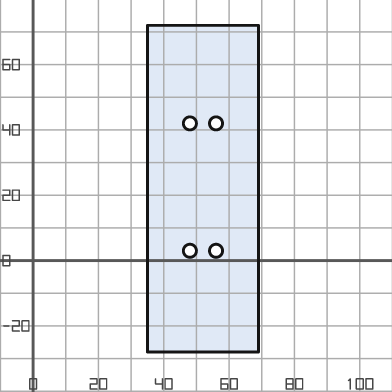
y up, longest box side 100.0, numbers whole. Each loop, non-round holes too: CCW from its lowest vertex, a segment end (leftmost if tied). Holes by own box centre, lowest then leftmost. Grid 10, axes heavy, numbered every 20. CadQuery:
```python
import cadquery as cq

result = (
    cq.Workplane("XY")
    .moveTo(35.0, -28.0)
    .lineTo(69.0, -28.0)
    .lineTo(69.0, 72.0)
    .lineTo(35.0, 72.0)
    .close()
    .moveTo(48.0, 3.0)
    .circle(2.0)
    .moveTo(56.0, 3.0)
    .circle(2.0)
    .moveTo(48.0, 42.0)
    .circle(2.0)
    .moveTo(56.0, 42.0)
    .circle(2.0)
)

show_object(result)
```